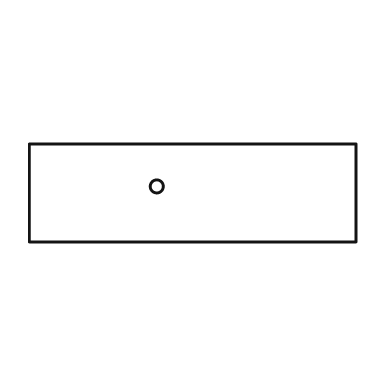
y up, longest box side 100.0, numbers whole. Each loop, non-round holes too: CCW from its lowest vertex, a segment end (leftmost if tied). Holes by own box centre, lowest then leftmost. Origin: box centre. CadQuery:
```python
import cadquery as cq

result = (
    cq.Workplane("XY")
    .moveTo(-50.0, -15.0)
    .lineTo(50.0, -15.0)
    .lineTo(50.0, 15.0)
    .lineTo(-50.0, 15.0)
    .close()
    .moveTo(-11.0, 2.0)
    .circle(2.0)
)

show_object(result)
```